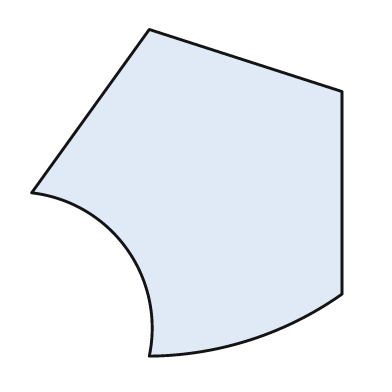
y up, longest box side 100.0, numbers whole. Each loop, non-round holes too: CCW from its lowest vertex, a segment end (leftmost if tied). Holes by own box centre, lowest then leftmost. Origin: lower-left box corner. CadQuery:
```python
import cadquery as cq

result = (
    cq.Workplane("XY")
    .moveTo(36.0, 0.0)
    .threePointArc((67.0, 5.0), (95.0, 19.0))
    .lineTo(95.0, 81.0)
    .lineTo(36.0, 100.0)
    .lineTo(0.0, 50.0)
    .threePointArc((29.0, 33.0), (36.0, 0.0))
    .close()
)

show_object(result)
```